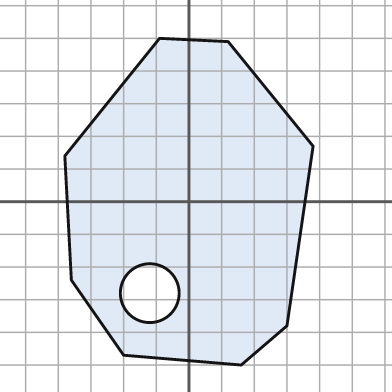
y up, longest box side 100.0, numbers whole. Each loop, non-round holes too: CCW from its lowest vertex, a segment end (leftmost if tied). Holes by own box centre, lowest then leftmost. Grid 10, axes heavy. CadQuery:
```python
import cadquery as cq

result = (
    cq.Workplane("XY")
    .moveTo(16.0, -50.0)
    .lineTo(30.0, -38.0)
    .lineTo(38.0, 17.0)
    .lineTo(12.0, 49.0)
    .lineTo(-9.0, 50.0)
    .lineTo(-38.0, 14.0)
    .lineTo(-36.0, -24.0)
    .lineTo(-20.0, -47.0)
    .close()
    .moveTo(-12.0, -28.0)
    .circle(9.0)
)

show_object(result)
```